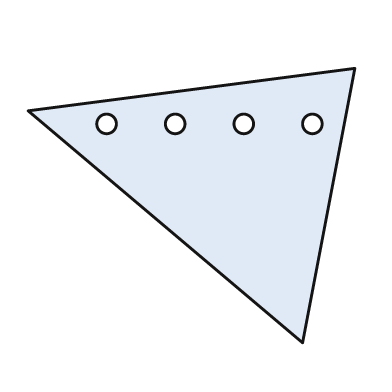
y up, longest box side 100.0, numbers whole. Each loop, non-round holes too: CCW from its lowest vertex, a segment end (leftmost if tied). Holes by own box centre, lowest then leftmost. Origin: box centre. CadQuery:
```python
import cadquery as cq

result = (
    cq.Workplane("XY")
    .moveTo(34.0, -42.0)
    .lineTo(50.0, 42.0)
    .lineTo(-50.0, 29.0)
    .close()
    .moveTo(-26.0, 25.0)
    .circle(3.0)
    .moveTo(-5.0, 25.0)
    .circle(3.0)
    .moveTo(16.0, 25.0)
    .circle(3.0)
    .moveTo(37.0, 25.0)
    .circle(3.0)
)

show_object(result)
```